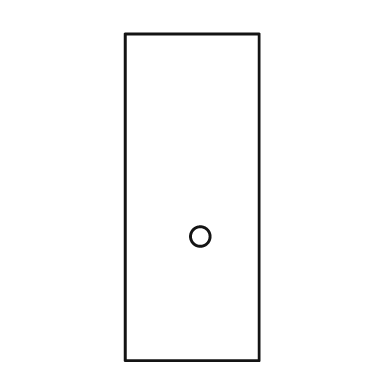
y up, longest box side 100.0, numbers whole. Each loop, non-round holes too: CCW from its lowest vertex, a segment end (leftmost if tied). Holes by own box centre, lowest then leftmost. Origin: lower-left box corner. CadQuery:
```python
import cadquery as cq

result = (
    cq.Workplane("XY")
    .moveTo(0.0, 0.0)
    .lineTo(41.0, 0.0)
    .lineTo(41.0, 100.0)
    .lineTo(0.0, 100.0)
    .close()
    .moveTo(23.0, 38.0)
    .circle(3.0)
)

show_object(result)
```